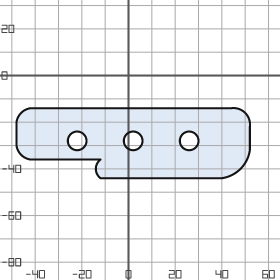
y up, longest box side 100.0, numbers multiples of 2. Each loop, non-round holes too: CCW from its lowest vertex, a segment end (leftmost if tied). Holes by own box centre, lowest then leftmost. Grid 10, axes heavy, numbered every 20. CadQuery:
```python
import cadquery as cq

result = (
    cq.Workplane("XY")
    .moveTo(-12.0, -44.0)
    .lineTo(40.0, -44.0)
    .threePointArc((48.0, -40.0), (52.0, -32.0))
    .lineTo(52.0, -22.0)
    .threePointArc((50.0, -16.0), (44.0, -14.0))
    .lineTo(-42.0, -14.0)
    .threePointArc((-46.0, -16.0), (-48.0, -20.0))
    .lineTo(-48.0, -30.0)
    .threePointArc((-46.0, -34.0), (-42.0, -36.0))
    .lineTo(-12.0, -36.0)
    .threePointArc((-14.0, -40.0), (-12.0, -44.0))
    .close()
    .moveTo(-22.0, -28.0)
    .circle(4.0)
    .moveTo(2.0, -28.0)
    .circle(4.0)
    .moveTo(26.0, -28.0)
    .circle(4.0)
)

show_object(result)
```